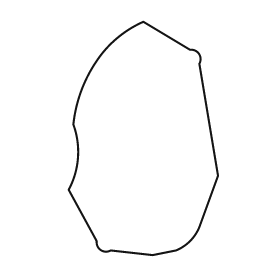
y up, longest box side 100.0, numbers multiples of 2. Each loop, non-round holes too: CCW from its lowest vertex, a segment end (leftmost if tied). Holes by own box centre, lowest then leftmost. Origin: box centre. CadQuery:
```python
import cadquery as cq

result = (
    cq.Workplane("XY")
    .moveTo(4.0, -50.0)
    .lineTo(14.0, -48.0)
    .threePointArc((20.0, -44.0), (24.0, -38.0))
    .lineTo(32.0, -16.0)
    .lineTo(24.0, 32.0)
    .threePointArc((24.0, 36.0), (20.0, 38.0))
    .lineTo(0.0, 50.0)
    .threePointArc((-10.0, 44.0), (-18.0, 36.0))
    .threePointArc((-26.0, 22.0), (-30.0, 6.0))
    .threePointArc((-28.0, -8.0), (-32.0, -22.0))
    .lineTo(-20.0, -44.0)
    .threePointArc((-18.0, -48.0), (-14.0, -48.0))
    .close()
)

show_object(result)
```